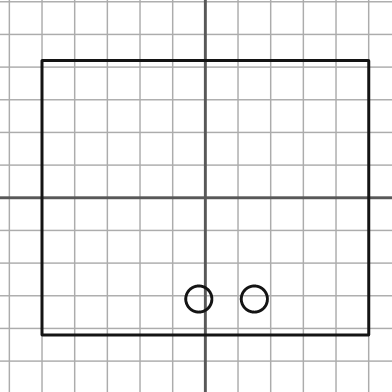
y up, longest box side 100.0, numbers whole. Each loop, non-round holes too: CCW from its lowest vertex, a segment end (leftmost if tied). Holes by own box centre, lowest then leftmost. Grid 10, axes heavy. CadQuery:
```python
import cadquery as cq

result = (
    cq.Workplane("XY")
    .moveTo(-50.0, -42.0)
    .lineTo(50.0, -42.0)
    .lineTo(50.0, 42.0)
    .lineTo(-50.0, 42.0)
    .close()
    .moveTo(-2.0, -31.0)
    .circle(4.0)
    .moveTo(15.0, -31.0)
    .circle(4.0)
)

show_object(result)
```